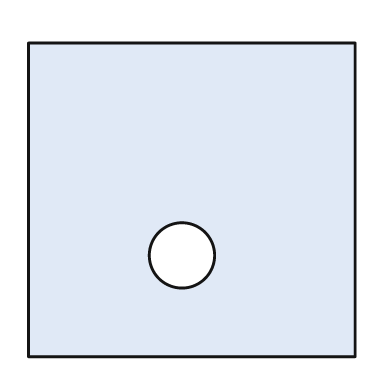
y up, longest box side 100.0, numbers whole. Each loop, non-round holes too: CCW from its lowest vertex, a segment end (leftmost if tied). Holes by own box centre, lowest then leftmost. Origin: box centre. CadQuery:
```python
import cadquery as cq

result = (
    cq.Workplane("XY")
    .moveTo(-50.0, -48.0)
    .lineTo(50.0, -48.0)
    .lineTo(50.0, 48.0)
    .lineTo(-50.0, 48.0)
    .close()
    .moveTo(-3.0, -17.0)
    .circle(10.0)
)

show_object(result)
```